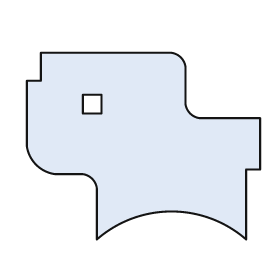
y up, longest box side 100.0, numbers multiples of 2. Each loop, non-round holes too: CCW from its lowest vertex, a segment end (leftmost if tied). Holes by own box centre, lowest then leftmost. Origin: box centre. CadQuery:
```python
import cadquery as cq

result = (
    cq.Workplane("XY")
    .moveTo(-20.0, -40.0)
    .threePointArc((12.0, -28.0), (44.0, -40.0))
    .lineTo(44.0, -10.0)
    .lineTo(50.0, -10.0)
    .lineTo(50.0, 12.0)
    .lineTo(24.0, 12.0)
    .threePointArc((20.0, 14.0), (18.0, 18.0))
    .lineTo(18.0, 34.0)
    .threePointArc((16.0, 38.0), (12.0, 40.0))
    .lineTo(-44.0, 40.0)
    .lineTo(-44.0, 28.0)
    .lineTo(-50.0, 28.0)
    .lineTo(-50.0, 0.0)
    .threePointArc((-46.0, -8.0), (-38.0, -12.0))
    .lineTo(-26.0, -12.0)
    .threePointArc((-22.0, -14.0), (-20.0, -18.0))
    .close()
    .moveTo(-26.0, 14.0)
    .lineTo(-18.0, 14.0)
    .lineTo(-18.0, 22.0)
    .lineTo(-26.0, 22.0)
    .close()
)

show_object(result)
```